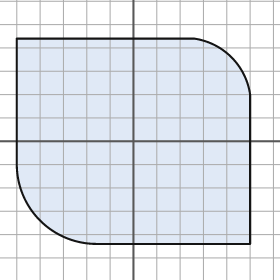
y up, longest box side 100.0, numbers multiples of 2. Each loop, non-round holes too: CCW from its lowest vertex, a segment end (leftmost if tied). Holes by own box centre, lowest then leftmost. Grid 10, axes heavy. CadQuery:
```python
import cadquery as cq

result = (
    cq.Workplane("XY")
    .moveTo(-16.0, -44.0)
    .lineTo(50.0, -44.0)
    .lineTo(50.0, 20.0)
    .threePointArc((42.0, 36.0), (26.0, 44.0))
    .lineTo(-50.0, 44.0)
    .lineTo(-50.0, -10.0)
    .threePointArc((-40.0, -34.0), (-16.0, -44.0))
    .close()
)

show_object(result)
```